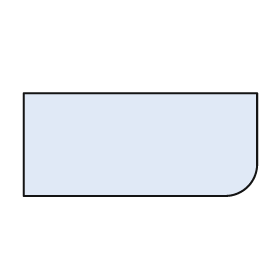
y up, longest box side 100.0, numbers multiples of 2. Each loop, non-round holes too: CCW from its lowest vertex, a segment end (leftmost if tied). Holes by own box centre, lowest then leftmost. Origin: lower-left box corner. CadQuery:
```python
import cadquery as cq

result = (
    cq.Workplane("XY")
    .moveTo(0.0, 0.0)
    .lineTo(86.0, 0.0)
    .threePointArc((96.0, 4.0), (100.0, 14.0))
    .lineTo(100.0, 44.0)
    .lineTo(0.0, 44.0)
    .close()
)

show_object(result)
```